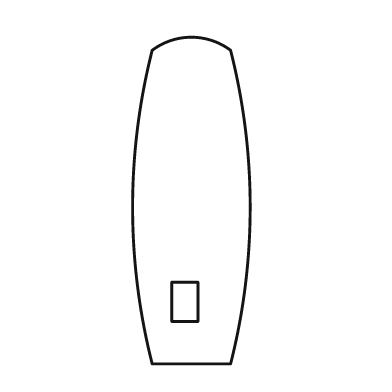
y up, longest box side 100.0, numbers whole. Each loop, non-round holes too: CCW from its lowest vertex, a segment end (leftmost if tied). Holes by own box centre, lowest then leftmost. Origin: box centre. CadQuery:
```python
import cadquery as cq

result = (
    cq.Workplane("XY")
    .moveTo(-12.0, -50.0)
    .lineTo(12.0, -50.0)
    .threePointArc((18.0, -2.0), (12.0, 46.0))
    .threePointArc((0.0, 50.0), (-12.0, 46.0))
    .threePointArc((-18.0, -2.0), (-12.0, -50.0))
    .close()
    .moveTo(-6.0, -37.0)
    .lineTo(2.0, -37.0)
    .lineTo(2.0, -25.0)
    .lineTo(-6.0, -25.0)
    .close()
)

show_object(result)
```